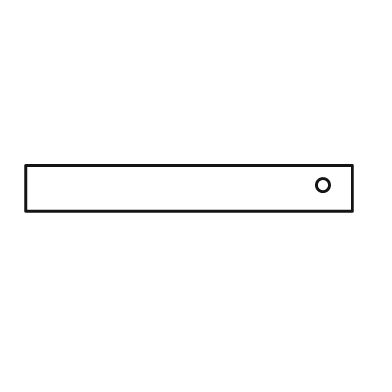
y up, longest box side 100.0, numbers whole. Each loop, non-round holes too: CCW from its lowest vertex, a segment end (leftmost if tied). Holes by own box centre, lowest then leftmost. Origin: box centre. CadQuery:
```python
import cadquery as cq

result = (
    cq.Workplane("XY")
    .moveTo(-50.0, -7.0)
    .lineTo(50.0, -7.0)
    .lineTo(50.0, 7.0)
    .lineTo(-50.0, 7.0)
    .close()
    .moveTo(41.0, 1.0)
    .circle(2.0)
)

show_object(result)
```